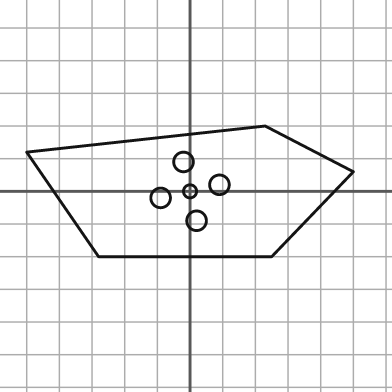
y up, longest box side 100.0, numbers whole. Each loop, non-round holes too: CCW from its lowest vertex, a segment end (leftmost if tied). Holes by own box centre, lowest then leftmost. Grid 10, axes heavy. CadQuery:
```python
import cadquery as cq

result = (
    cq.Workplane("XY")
    .moveTo(-28.0, -20.0)
    .lineTo(25.0, -20.0)
    .lineTo(50.0, 6.0)
    .lineTo(23.0, 20.0)
    .lineTo(-50.0, 12.0)
    .close()
    .moveTo(2.0, -9.0)
    .circle(3.0)
    .moveTo(-9.0, -2.0)
    .circle(3.0)
    .moveTo(0.0, 0.0)
    .circle(2.0)
    .moveTo(9.0, 2.0)
    .circle(3.0)
    .moveTo(-2.0, 9.0)
    .circle(3.0)
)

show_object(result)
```